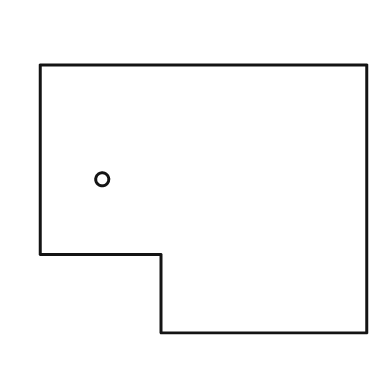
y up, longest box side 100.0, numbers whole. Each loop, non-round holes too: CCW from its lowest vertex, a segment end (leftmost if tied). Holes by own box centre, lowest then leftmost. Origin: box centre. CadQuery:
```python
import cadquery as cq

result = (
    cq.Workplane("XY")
    .moveTo(-13.0, -41.0)
    .lineTo(50.0, -41.0)
    .lineTo(50.0, 41.0)
    .lineTo(-50.0, 41.0)
    .lineTo(-50.0, -17.0)
    .lineTo(-13.0, -17.0)
    .close()
    .moveTo(-31.0, 6.0)
    .circle(2.0)
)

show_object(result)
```